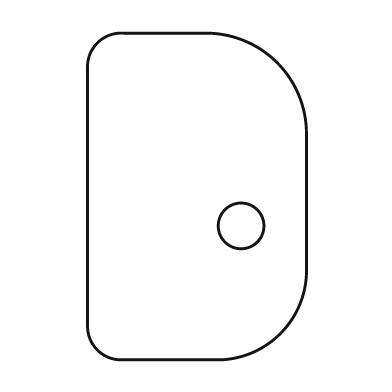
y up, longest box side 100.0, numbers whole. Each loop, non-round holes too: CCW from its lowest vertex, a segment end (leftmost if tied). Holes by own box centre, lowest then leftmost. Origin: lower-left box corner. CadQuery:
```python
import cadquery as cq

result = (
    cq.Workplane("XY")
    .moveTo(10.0, 0.0)
    .lineTo(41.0, 0.0)
    .threePointArc((59.0, 8.0), (67.0, 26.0))
    .lineTo(67.0, 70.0)
    .threePointArc((58.0, 91.0), (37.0, 100.0))
    .lineTo(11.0, 100.0)
    .threePointArc((3.0, 97.0), (0.0, 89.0))
    .lineTo(0.0, 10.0)
    .threePointArc((3.0, 3.0), (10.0, 0.0))
    .close()
    .moveTo(47.0, 41.0)
    .circle(7.0)
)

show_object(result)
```